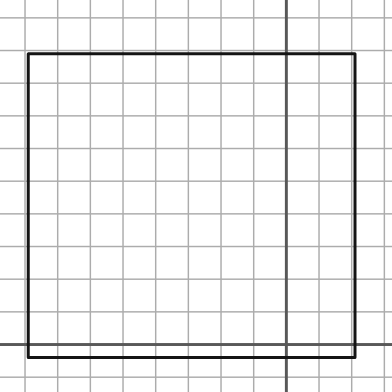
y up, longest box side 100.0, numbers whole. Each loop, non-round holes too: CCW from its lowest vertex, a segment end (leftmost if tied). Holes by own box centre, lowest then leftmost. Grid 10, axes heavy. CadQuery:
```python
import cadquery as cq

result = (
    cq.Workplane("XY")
    .moveTo(-79.0, -4.0)
    .lineTo(21.0, -4.0)
    .lineTo(21.0, 89.0)
    .lineTo(-79.0, 89.0)
    .close()
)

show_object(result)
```